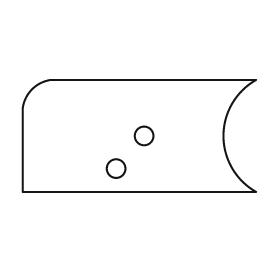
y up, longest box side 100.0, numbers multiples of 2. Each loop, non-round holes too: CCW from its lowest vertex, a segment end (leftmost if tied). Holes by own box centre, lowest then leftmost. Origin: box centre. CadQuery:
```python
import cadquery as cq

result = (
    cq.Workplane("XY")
    .moveTo(-50.0, -24.0)
    .lineTo(50.0, -24.0)
    .threePointArc((36.0, 0.0), (50.0, 24.0))
    .lineTo(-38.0, 24.0)
    .threePointArc((-46.0, 20.0), (-50.0, 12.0))
    .close()
    .moveTo(-10.0, -14.0)
    .circle(4.0)
    .moveTo(2.0, 0.0)
    .circle(4.0)
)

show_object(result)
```